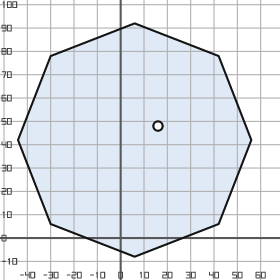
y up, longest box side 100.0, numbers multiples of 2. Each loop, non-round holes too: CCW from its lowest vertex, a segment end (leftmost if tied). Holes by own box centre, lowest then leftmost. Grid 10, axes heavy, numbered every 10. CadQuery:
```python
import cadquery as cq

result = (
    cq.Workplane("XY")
    .moveTo(6.0, -8.0)
    .lineTo(42.0, 6.0)
    .lineTo(56.0, 42.0)
    .lineTo(42.0, 78.0)
    .lineTo(6.0, 92.0)
    .lineTo(-30.0, 78.0)
    .lineTo(-44.0, 42.0)
    .lineTo(-30.0, 6.0)
    .close()
    .moveTo(16.0, 48.0)
    .circle(2.0)
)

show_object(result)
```